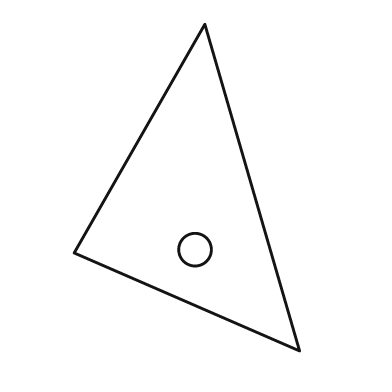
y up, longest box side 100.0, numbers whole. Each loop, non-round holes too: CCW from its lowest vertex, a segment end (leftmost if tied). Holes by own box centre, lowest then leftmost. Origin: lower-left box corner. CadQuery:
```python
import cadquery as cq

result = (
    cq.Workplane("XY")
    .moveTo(69.0, 0.0)
    .lineTo(40.0, 100.0)
    .lineTo(0.0, 30.0)
    .close()
    .moveTo(37.0, 31.0)
    .circle(5.0)
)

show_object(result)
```